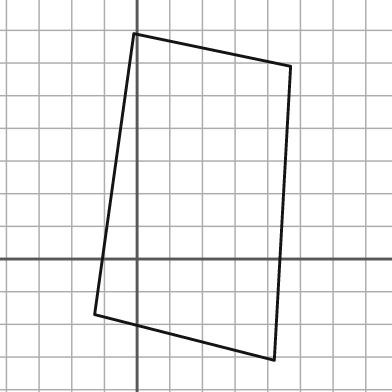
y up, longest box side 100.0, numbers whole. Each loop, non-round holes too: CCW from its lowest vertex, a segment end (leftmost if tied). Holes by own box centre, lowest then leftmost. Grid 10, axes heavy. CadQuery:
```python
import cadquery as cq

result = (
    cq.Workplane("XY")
    .moveTo(42.0, -31.0)
    .lineTo(47.0, 59.0)
    .lineTo(-1.0, 69.0)
    .lineTo(-13.0, -17.0)
    .close()
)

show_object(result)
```